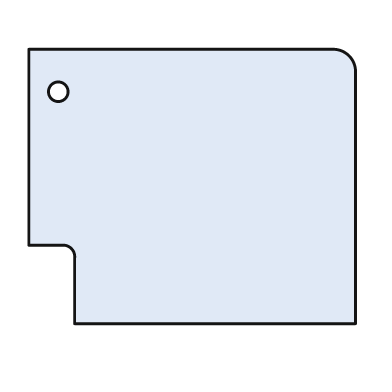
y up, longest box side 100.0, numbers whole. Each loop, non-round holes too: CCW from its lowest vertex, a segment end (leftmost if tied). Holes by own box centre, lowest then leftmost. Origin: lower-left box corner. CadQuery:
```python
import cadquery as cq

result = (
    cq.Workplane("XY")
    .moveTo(14.0, 0.0)
    .lineTo(100.0, 0.0)
    .lineTo(100.0, 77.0)
    .threePointArc((98.0, 82.0), (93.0, 84.0))
    .lineTo(0.0, 84.0)
    .lineTo(0.0, 24.0)
    .lineTo(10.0, 24.0)
    .threePointArc((13.0, 23.0), (14.0, 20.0))
    .close()
    .moveTo(9.0, 71.0)
    .circle(3.0)
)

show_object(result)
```